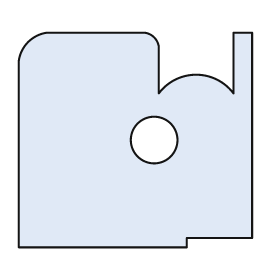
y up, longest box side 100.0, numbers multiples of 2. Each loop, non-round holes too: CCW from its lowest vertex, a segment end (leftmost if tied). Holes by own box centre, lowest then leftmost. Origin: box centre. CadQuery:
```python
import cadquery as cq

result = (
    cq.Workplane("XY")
    .moveTo(-50.0, -46.0)
    .lineTo(22.0, -46.0)
    .lineTo(22.0, -42.0)
    .lineTo(50.0, -42.0)
    .lineTo(50.0, 46.0)
    .lineTo(42.0, 46.0)
    .lineTo(42.0, 20.0)
    .threePointArc((26.0, 28.0), (10.0, 20.0))
    .lineTo(10.0, 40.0)
    .threePointArc((8.0, 44.0), (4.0, 46.0))
    .lineTo(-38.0, 46.0)
    .threePointArc((-46.0, 42.0), (-50.0, 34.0))
    .close()
    .moveTo(8.0, 0.0)
    .circle(10.0)
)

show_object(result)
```